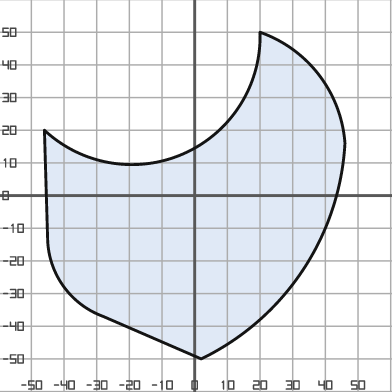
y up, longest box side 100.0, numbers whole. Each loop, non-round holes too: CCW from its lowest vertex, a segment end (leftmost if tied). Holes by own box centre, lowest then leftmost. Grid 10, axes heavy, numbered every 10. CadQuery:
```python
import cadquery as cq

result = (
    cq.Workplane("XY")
    .moveTo(2.0, -50.0)
    .threePointArc((33.0, -23.0), (46.0, 16.0))
    .threePointArc((38.0, 37.0), (20.0, 50.0))
    .threePointArc((-3.0, 13.0), (-46.0, 20.0))
    .lineTo(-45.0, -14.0)
    .threePointArc((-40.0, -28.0), (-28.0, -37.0))
    .close()
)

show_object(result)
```